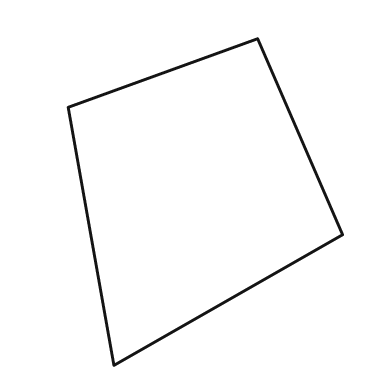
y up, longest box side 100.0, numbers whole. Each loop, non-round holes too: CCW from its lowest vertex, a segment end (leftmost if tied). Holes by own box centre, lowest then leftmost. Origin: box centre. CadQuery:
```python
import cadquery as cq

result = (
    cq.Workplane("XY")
    .moveTo(-28.0, -50.0)
    .lineTo(42.0, -10.0)
    .lineTo(16.0, 50.0)
    .lineTo(-42.0, 29.0)
    .close()
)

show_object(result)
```